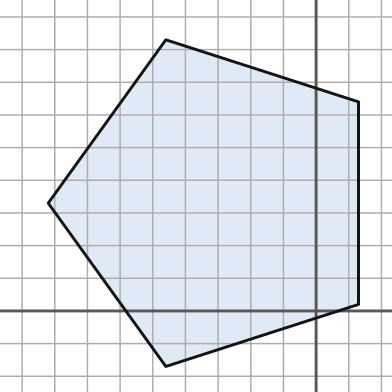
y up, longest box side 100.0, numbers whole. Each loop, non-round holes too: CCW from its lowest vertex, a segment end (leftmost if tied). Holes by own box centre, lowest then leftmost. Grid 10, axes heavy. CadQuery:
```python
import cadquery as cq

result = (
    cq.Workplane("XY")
    .moveTo(-46.0, -17.0)
    .lineTo(13.0, 2.0)
    .lineTo(13.0, 64.0)
    .lineTo(-46.0, 83.0)
    .lineTo(-82.0, 33.0)
    .close()
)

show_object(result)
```